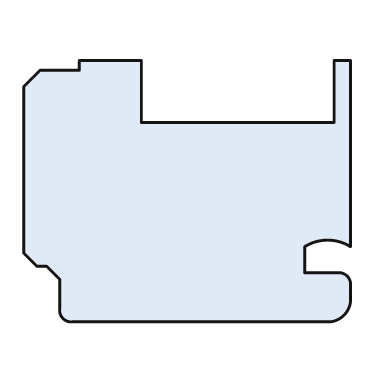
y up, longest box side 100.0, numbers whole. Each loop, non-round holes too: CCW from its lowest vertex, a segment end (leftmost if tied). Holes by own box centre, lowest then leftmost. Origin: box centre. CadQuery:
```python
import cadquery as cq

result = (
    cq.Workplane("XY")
    .moveTo(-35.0, -40.0)
    .lineTo(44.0, -40.0)
    .threePointArc((48.0, -38.0), (50.0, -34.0))
    .lineTo(50.0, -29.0)
    .threePointArc((49.0, -26.0), (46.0, -25.0))
    .lineTo(36.0, -25.0)
    .lineTo(36.0, -17.0)
    .threePointArc((43.0, -15.0), (50.0, -17.0))
    .lineTo(50.0, 40.0)
    .lineTo(45.0, 40.0)
    .lineTo(45.0, 21.0)
    .lineTo(-14.0, 21.0)
    .lineTo(-14.0, 40.0)
    .lineTo(-33.0, 40.0)
    .lineTo(-33.0, 37.0)
    .lineTo(-45.0, 37.0)
    .lineTo(-50.0, 32.0)
    .lineTo(-50.0, -19.0)
    .lineTo(-46.0, -23.0)
    .lineTo(-43.0, -23.0)
    .lineTo(-39.0, -27.0)
    .lineTo(-39.0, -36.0)
    .threePointArc((-38.0, -39.0), (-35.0, -40.0))
    .close()
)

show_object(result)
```